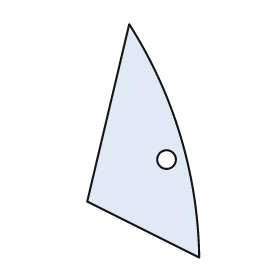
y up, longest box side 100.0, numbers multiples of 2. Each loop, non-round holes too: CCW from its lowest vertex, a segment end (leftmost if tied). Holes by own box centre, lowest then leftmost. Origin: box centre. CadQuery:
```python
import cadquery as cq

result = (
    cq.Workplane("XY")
    .moveTo(24.0, -50.0)
    .threePointArc((16.0, 2.0), (-6.0, 50.0))
    .lineTo(-24.0, -26.0)
    .close()
    .moveTo(10.0, -8.0)
    .circle(4.0)
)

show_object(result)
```